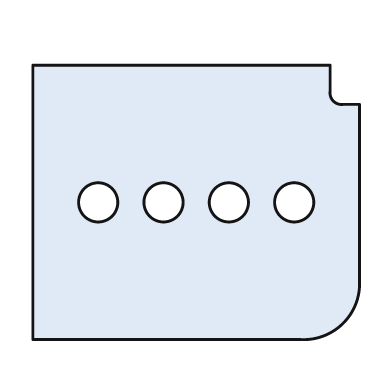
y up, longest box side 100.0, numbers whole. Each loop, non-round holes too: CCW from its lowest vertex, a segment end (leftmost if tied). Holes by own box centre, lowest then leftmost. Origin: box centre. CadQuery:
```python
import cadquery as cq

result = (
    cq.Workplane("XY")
    .moveTo(-50.0, -42.0)
    .lineTo(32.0, -42.0)
    .threePointArc((45.0, -37.0), (50.0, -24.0))
    .lineTo(50.0, 30.0)
    .lineTo(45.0, 30.0)
    .threePointArc((42.0, 31.0), (41.0, 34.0))
    .lineTo(41.0, 42.0)
    .lineTo(-50.0, 42.0)
    .close()
    .moveTo(-30.0, 0.0)
    .circle(6.0)
    .moveTo(-10.0, 0.0)
    .circle(6.0)
    .moveTo(10.0, 0.0)
    .circle(6.0)
    .moveTo(30.0, 0.0)
    .circle(6.0)
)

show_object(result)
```